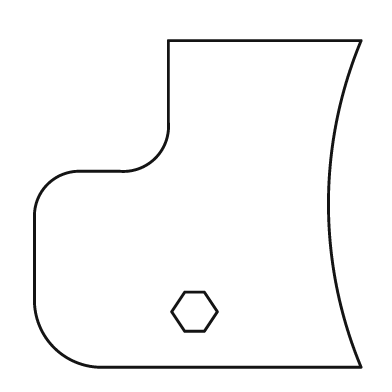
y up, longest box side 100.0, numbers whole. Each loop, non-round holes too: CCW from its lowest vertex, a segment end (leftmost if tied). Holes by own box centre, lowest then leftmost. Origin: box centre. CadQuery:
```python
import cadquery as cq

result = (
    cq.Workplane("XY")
    .moveTo(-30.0, -50.0)
    .lineTo(50.0, -50.0)
    .threePointArc((40.0, 0.0), (50.0, 50.0))
    .lineTo(-9.0, 50.0)
    .lineTo(-9.0, 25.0)
    .threePointArc((-13.0, 14.0), (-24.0, 10.0))
    .lineTo(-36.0, 10.0)
    .threePointArc((-46.0, 6.0), (-50.0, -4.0))
    .lineTo(-50.0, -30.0)
    .threePointArc((-44.0, -44.0), (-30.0, -50.0))
    .close()
    .moveTo(-4.0, -39.0)
    .lineTo(2.0, -39.0)
    .lineTo(6.0, -33.0)
    .lineTo(2.0, -27.0)
    .lineTo(-4.0, -27.0)
    .lineTo(-8.0, -33.0)
    .close()
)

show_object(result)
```